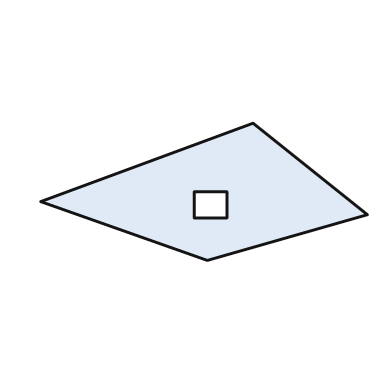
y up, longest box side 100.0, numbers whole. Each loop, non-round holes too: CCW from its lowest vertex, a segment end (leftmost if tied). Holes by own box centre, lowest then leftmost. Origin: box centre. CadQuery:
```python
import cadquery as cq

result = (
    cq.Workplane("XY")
    .moveTo(1.0, -21.0)
    .lineTo(50.0, -7.0)
    .lineTo(15.0, 21.0)
    .lineTo(-50.0, -3.0)
    .close()
    .moveTo(-3.0, -8.0)
    .lineTo(7.0, -8.0)
    .lineTo(7.0, 0.0)
    .lineTo(-3.0, 0.0)
    .close()
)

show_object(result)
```